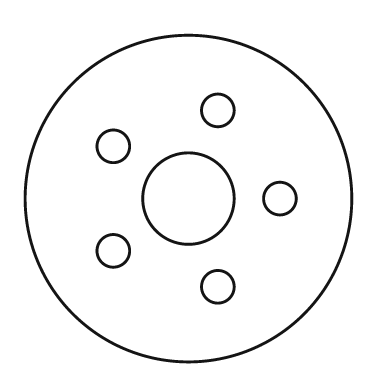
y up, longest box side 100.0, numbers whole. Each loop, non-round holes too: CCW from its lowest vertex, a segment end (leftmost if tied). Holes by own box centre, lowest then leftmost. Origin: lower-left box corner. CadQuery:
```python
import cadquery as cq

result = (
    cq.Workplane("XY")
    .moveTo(50.0, 50.0)
    .circle(50.0)
    .moveTo(59.0, 23.0)
    .circle(5.0)
    .moveTo(27.0, 34.0)
    .circle(5.0)
    .moveTo(50.0, 50.0)
    .circle(14.0)
    .moveTo(78.0, 50.0)
    .circle(5.0)
    .moveTo(27.0, 66.0)
    .circle(5.0)
    .moveTo(59.0, 77.0)
    .circle(5.0)
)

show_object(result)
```